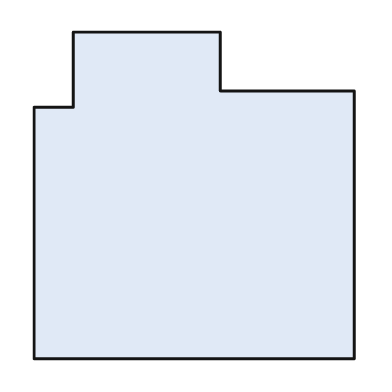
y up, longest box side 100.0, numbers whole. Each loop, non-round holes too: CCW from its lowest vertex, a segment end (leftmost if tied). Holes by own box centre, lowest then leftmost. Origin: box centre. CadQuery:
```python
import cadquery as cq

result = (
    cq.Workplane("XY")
    .moveTo(-49.0, -50.0)
    .lineTo(49.0, -50.0)
    .lineTo(49.0, 32.0)
    .lineTo(8.0, 32.0)
    .lineTo(8.0, 50.0)
    .lineTo(-37.0, 50.0)
    .lineTo(-37.0, 27.0)
    .lineTo(-49.0, 27.0)
    .close()
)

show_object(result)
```